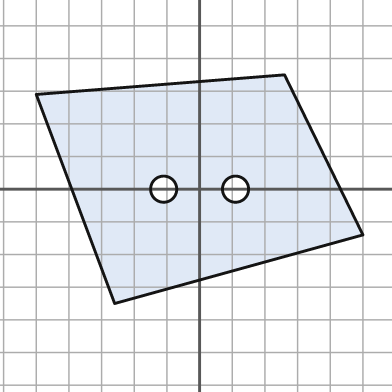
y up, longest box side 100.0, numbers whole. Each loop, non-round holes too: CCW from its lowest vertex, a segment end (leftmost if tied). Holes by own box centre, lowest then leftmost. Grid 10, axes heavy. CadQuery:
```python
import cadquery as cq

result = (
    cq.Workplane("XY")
    .moveTo(-26.0, -35.0)
    .lineTo(50.0, -14.0)
    .lineTo(26.0, 35.0)
    .lineTo(-50.0, 29.0)
    .close()
    .moveTo(-11.0, 0.0)
    .circle(4.0)
    .moveTo(11.0, 0.0)
    .circle(4.0)
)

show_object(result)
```